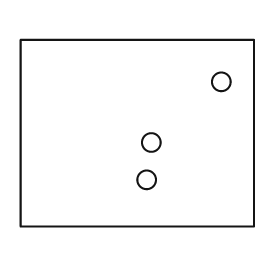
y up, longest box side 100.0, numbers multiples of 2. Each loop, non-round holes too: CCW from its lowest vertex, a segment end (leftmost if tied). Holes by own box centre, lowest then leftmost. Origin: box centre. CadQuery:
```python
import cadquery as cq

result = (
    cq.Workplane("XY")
    .moveTo(-50.0, -40.0)
    .lineTo(50.0, -40.0)
    .lineTo(50.0, 40.0)
    .lineTo(-50.0, 40.0)
    .close()
    .moveTo(4.0, -20.0)
    .circle(4.0)
    .moveTo(6.0, -4.0)
    .circle(4.0)
    .moveTo(36.0, 22.0)
    .circle(4.0)
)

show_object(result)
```